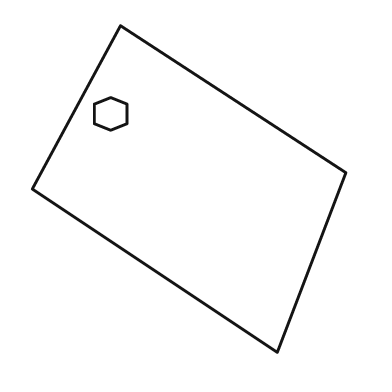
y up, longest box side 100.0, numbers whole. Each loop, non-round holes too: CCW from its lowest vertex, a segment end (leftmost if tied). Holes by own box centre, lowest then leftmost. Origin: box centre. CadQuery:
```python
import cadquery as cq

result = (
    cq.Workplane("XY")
    .moveTo(27.0, -50.0)
    .lineTo(48.0, 5.0)
    .lineTo(-21.0, 50.0)
    .lineTo(-48.0, 0.0)
    .close()
    .moveTo(-24.0, 18.0)
    .lineTo(-19.0, 20.0)
    .lineTo(-19.0, 26.0)
    .lineTo(-24.0, 28.0)
    .lineTo(-29.0, 26.0)
    .lineTo(-29.0, 20.0)
    .close()
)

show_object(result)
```